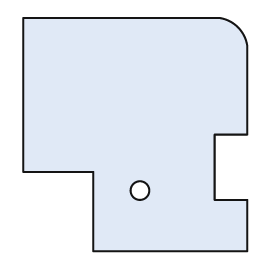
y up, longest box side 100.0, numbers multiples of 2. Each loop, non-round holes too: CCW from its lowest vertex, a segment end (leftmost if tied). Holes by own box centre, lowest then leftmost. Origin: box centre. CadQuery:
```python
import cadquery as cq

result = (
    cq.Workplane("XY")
    .moveTo(-18.0, -50.0)
    .lineTo(48.0, -50.0)
    .lineTo(48.0, -28.0)
    .lineTo(34.0, -28.0)
    .lineTo(34.0, 0.0)
    .lineTo(48.0, 0.0)
    .lineTo(48.0, 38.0)
    .threePointArc((44.0, 46.0), (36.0, 50.0))
    .lineTo(-48.0, 50.0)
    .lineTo(-48.0, -16.0)
    .lineTo(-18.0, -16.0)
    .close()
    .moveTo(2.0, -24.0)
    .circle(4.0)
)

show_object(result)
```